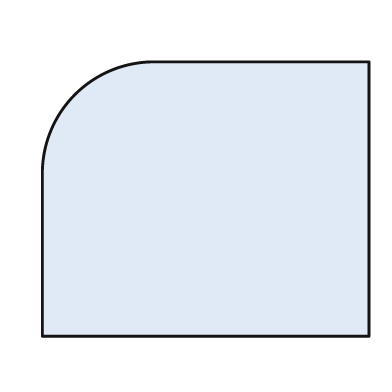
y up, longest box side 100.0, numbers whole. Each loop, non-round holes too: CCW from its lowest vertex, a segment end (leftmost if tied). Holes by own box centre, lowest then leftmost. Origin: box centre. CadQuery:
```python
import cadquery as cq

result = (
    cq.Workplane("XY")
    .moveTo(-50.0, -42.0)
    .lineTo(50.0, -42.0)
    .lineTo(50.0, 42.0)
    .lineTo(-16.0, 42.0)
    .threePointArc((-40.0, 32.0), (-50.0, 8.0))
    .close()
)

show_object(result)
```